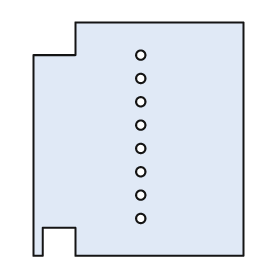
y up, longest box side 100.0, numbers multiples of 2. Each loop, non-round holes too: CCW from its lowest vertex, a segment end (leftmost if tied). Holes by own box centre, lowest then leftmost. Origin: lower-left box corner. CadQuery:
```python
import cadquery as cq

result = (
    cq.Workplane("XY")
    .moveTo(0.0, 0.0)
    .lineTo(4.0, 0.0)
    .lineTo(4.0, 12.0)
    .lineTo(18.0, 12.0)
    .lineTo(18.0, 0.0)
    .lineTo(90.0, 0.0)
    .lineTo(90.0, 100.0)
    .lineTo(18.0, 100.0)
    .lineTo(18.0, 86.0)
    .lineTo(0.0, 86.0)
    .close()
    .moveTo(46.0, 16.0)
    .circle(2.0)
    .moveTo(46.0, 26.0)
    .circle(2.0)
    .moveTo(46.0, 36.0)
    .circle(2.0)
    .moveTo(46.0, 46.0)
    .circle(2.0)
    .moveTo(46.0, 56.0)
    .circle(2.0)
    .moveTo(46.0, 66.0)
    .circle(2.0)
    .moveTo(46.0, 76.0)
    .circle(2.0)
    .moveTo(46.0, 86.0)
    .circle(2.0)
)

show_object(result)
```